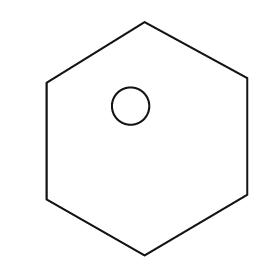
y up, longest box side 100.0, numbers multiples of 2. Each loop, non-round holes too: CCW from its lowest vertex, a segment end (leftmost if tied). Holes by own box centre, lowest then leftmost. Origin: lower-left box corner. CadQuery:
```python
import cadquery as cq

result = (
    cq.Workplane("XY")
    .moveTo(42.0, 0.0)
    .lineTo(86.0, 26.0)
    .lineTo(86.0, 76.0)
    .lineTo(42.0, 100.0)
    .lineTo(0.0, 74.0)
    .lineTo(0.0, 24.0)
    .close()
    .moveTo(36.0, 64.0)
    .circle(8.0)
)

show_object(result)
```